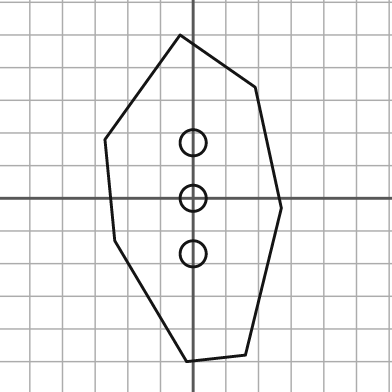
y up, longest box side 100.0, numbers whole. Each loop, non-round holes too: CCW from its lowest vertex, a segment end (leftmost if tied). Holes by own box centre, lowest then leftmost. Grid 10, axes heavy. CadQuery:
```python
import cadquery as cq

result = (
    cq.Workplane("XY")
    .moveTo(-2.0, -50.0)
    .lineTo(16.0, -48.0)
    .lineTo(27.0, -3.0)
    .lineTo(19.0, 34.0)
    .lineTo(-4.0, 50.0)
    .lineTo(-27.0, 18.0)
    .lineTo(-24.0, -13.0)
    .close()
    .moveTo(0.0, -17.0)
    .circle(4.0)
    .moveTo(0.0, 0.0)
    .circle(4.0)
    .moveTo(0.0, 17.0)
    .circle(4.0)
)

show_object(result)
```